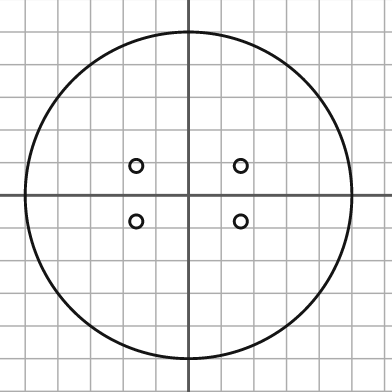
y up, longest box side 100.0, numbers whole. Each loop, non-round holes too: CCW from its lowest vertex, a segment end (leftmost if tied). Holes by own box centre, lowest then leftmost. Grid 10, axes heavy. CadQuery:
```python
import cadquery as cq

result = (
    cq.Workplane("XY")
    .moveTo(0.0, 0.0)
    .circle(50.0)
    .moveTo(-16.0, -8.0)
    .circle(2.0)
    .moveTo(16.0, -8.0)
    .circle(2.0)
    .moveTo(-16.0, 9.0)
    .circle(2.0)
    .moveTo(16.0, 9.0)
    .circle(2.0)
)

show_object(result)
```